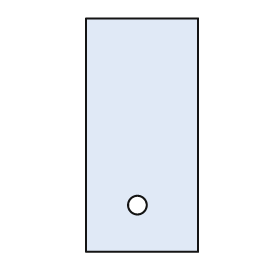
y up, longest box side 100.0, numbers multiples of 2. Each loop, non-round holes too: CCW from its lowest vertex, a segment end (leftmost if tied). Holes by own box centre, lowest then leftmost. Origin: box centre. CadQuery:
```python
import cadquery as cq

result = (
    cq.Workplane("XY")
    .moveTo(-24.0, -50.0)
    .lineTo(24.0, -50.0)
    .lineTo(24.0, 50.0)
    .lineTo(-24.0, 50.0)
    .close()
    .moveTo(-2.0, -30.0)
    .circle(4.0)
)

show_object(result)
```